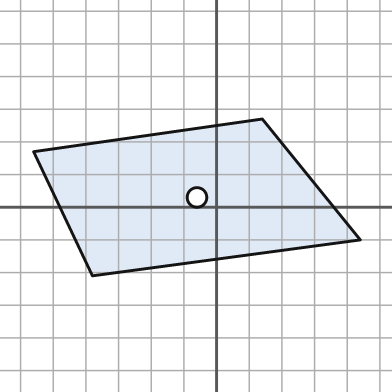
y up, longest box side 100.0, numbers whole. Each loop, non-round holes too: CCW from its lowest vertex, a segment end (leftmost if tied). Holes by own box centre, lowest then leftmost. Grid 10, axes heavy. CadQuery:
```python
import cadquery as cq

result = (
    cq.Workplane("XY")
    .moveTo(-38.0, -21.0)
    .lineTo(44.0, -10.0)
    .lineTo(14.0, 27.0)
    .lineTo(-56.0, 17.0)
    .close()
    .moveTo(-6.0, 3.0)
    .circle(3.0)
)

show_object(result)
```